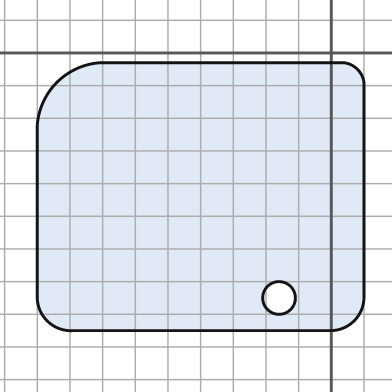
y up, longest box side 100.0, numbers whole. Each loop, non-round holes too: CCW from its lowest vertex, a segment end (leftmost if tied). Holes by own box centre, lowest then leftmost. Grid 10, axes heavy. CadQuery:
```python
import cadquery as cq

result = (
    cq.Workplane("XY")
    .moveTo(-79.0, -85.0)
    .lineTo(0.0, -85.0)
    .threePointArc((7.0, -82.0), (10.0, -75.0))
    .lineTo(10.0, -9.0)
    .threePointArc((8.0, -5.0), (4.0, -3.0))
    .lineTo(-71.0, -3.0)
    .threePointArc((-84.0, -9.0), (-90.0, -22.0))
    .lineTo(-90.0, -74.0)
    .threePointArc((-87.0, -82.0), (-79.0, -85.0))
    .close()
    .moveTo(-16.0, -75.0)
    .circle(5.0)
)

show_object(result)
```